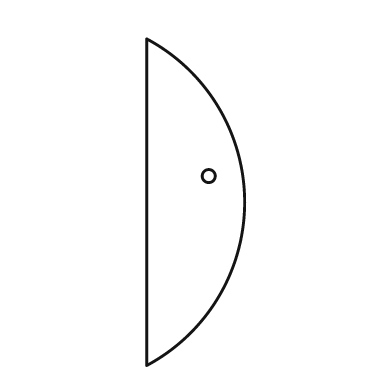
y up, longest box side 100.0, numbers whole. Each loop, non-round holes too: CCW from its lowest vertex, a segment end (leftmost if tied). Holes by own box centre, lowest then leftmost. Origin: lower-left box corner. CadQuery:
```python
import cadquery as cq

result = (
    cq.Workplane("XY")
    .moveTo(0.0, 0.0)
    .threePointArc((30.0, 50.0), (0.0, 100.0))
    .close()
    .moveTo(19.0, 58.0)
    .circle(2.0)
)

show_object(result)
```